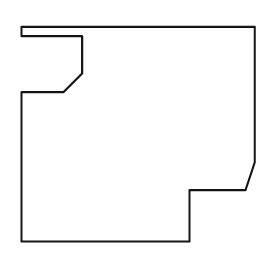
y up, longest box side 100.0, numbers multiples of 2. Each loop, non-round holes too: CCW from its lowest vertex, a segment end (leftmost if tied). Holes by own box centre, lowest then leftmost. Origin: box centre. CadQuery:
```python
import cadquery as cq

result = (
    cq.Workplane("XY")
    .moveTo(-50.0, -46.0)
    .lineTo(22.0, -46.0)
    .lineTo(22.0, -24.0)
    .lineTo(46.0, -24.0)
    .lineTo(50.0, -12.0)
    .lineTo(50.0, 46.0)
    .lineTo(-50.0, 46.0)
    .lineTo(-50.0, 42.0)
    .lineTo(-24.0, 42.0)
    .lineTo(-24.0, 26.0)
    .lineTo(-32.0, 18.0)
    .lineTo(-50.0, 18.0)
    .close()
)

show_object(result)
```